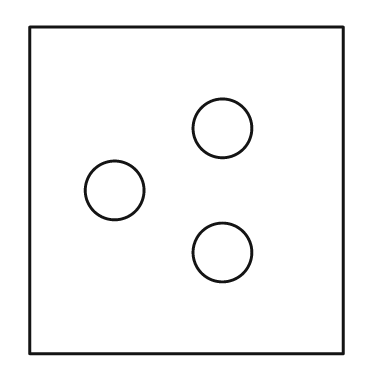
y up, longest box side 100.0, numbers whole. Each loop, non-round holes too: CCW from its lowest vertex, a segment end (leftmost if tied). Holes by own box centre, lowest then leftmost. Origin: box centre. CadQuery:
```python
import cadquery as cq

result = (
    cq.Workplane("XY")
    .moveTo(-48.0, -50.0)
    .lineTo(48.0, -50.0)
    .lineTo(48.0, 50.0)
    .lineTo(-48.0, 50.0)
    .close()
    .moveTo(11.0, -19.0)
    .circle(9.0)
    .moveTo(-22.0, 0.0)
    .circle(9.0)
    .moveTo(11.0, 19.0)
    .circle(9.0)
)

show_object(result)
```